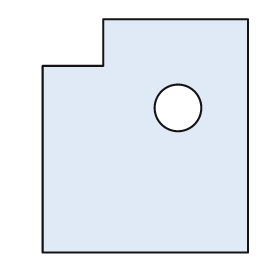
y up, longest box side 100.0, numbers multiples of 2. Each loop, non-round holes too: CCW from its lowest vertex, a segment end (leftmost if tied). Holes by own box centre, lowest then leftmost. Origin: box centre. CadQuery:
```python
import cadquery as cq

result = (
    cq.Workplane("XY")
    .moveTo(-44.0, -50.0)
    .lineTo(44.0, -50.0)
    .lineTo(44.0, 50.0)
    .lineTo(-18.0, 50.0)
    .lineTo(-18.0, 30.0)
    .lineTo(-44.0, 30.0)
    .close()
    .moveTo(14.0, 12.0)
    .circle(10.0)
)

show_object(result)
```